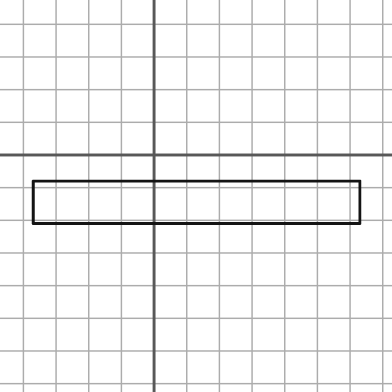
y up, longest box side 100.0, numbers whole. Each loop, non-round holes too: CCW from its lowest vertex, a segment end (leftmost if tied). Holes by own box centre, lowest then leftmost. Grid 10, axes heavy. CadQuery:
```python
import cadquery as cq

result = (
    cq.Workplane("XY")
    .moveTo(-37.0, -21.0)
    .lineTo(63.0, -21.0)
    .lineTo(63.0, -8.0)
    .lineTo(-37.0, -8.0)
    .close()
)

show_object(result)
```